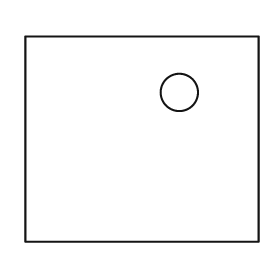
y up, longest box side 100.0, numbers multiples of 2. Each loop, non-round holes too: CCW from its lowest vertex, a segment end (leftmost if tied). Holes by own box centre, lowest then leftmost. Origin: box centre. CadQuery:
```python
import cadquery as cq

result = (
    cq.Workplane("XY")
    .moveTo(-50.0, -44.0)
    .lineTo(50.0, -44.0)
    .lineTo(50.0, 44.0)
    .lineTo(-50.0, 44.0)
    .close()
    .moveTo(16.0, 20.0)
    .circle(8.0)
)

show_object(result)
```